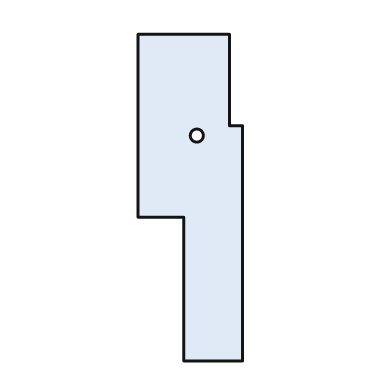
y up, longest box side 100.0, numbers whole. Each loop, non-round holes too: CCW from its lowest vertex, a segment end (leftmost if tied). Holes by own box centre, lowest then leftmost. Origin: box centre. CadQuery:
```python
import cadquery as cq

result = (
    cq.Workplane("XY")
    .moveTo(-2.0, -50.0)
    .lineTo(16.0, -50.0)
    .lineTo(16.0, 22.0)
    .lineTo(12.0, 22.0)
    .lineTo(12.0, 50.0)
    .lineTo(-16.0, 50.0)
    .lineTo(-16.0, -6.0)
    .lineTo(-2.0, -6.0)
    .close()
    .moveTo(2.0, 19.0)
    .circle(2.0)
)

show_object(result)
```